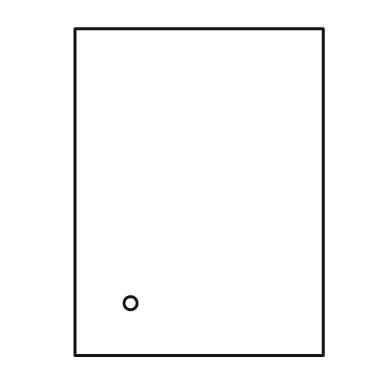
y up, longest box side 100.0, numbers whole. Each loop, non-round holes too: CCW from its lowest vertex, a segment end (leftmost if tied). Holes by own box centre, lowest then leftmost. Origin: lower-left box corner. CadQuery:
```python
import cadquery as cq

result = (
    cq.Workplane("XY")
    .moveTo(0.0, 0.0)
    .lineTo(76.0, 0.0)
    .lineTo(76.0, 100.0)
    .lineTo(0.0, 100.0)
    .close()
    .moveTo(17.0, 16.0)
    .circle(2.0)
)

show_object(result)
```